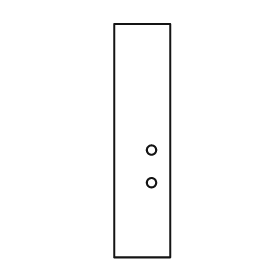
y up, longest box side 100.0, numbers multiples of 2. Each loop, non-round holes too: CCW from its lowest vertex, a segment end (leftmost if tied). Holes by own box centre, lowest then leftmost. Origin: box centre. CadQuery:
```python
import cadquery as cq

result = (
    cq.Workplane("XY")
    .moveTo(-12.0, -50.0)
    .lineTo(12.0, -50.0)
    .lineTo(12.0, 50.0)
    .lineTo(-12.0, 50.0)
    .close()
    .moveTo(4.0, -18.0)
    .circle(2.0)
    .moveTo(4.0, -4.0)
    .circle(2.0)
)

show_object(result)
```